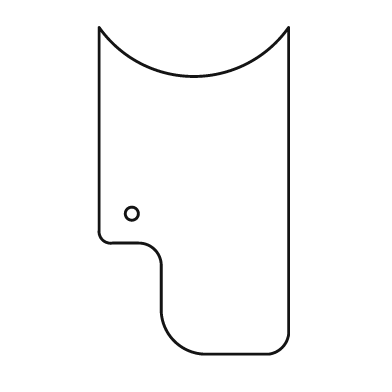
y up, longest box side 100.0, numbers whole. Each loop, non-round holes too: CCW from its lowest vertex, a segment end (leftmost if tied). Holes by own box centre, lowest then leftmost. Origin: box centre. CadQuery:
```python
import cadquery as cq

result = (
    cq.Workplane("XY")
    .moveTo(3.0, -50.0)
    .lineTo(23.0, -50.0)
    .threePointArc((27.0, -48.0), (29.0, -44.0))
    .lineTo(29.0, 50.0)
    .threePointArc((0.0, 35.0), (-29.0, 50.0))
    .lineTo(-29.0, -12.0)
    .threePointArc((-28.0, -15.0), (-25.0, -16.0))
    .lineTo(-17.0, -16.0)
    .threePointArc((-12.0, -18.0), (-10.0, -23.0))
    .lineTo(-10.0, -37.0)
    .threePointArc((-6.0, -46.0), (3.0, -50.0))
    .close()
    .moveTo(-19.0, -7.0)
    .circle(2.0)
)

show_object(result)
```